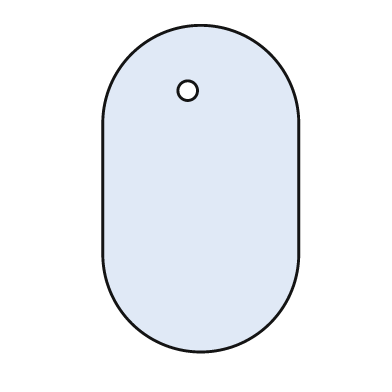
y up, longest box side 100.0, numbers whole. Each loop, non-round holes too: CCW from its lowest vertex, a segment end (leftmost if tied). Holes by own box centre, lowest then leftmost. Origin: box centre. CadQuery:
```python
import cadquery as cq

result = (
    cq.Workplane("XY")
    .moveTo(-30.0, -20.0)
    .threePointArc((0.0, -50.0), (30.0, -20.0))
    .lineTo(30.0, 20.0)
    .threePointArc((0.0, 50.0), (-30.0, 20.0))
    .close()
    .moveTo(-4.0, 30.0)
    .circle(3.0)
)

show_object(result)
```